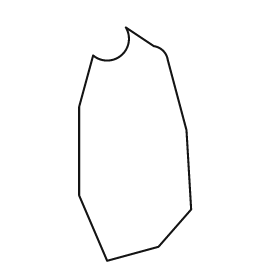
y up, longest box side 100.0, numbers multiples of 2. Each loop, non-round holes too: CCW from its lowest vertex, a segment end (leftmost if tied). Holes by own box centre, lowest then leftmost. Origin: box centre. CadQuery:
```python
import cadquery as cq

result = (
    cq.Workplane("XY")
    .moveTo(-12.0, -50.0)
    .lineTo(10.0, -44.0)
    .lineTo(24.0, -28.0)
    .lineTo(22.0, 6.0)
    .lineTo(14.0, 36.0)
    .threePointArc((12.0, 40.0), (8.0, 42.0))
    .lineTo(-4.0, 50.0)
    .threePointArc((-6.0, 38.0), (-18.0, 38.0))
    .lineTo(-24.0, 16.0)
    .lineTo(-24.0, -22.0)
    .close()
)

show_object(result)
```